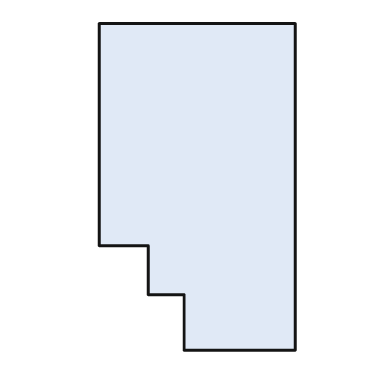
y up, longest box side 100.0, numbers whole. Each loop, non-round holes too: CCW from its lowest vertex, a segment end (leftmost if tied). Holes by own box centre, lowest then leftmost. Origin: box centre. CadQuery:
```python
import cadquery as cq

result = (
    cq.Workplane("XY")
    .moveTo(-4.0, -50.0)
    .lineTo(30.0, -50.0)
    .lineTo(30.0, 50.0)
    .lineTo(-30.0, 50.0)
    .lineTo(-30.0, -18.0)
    .lineTo(-15.0, -18.0)
    .lineTo(-15.0, -33.0)
    .lineTo(-4.0, -33.0)
    .close()
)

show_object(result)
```